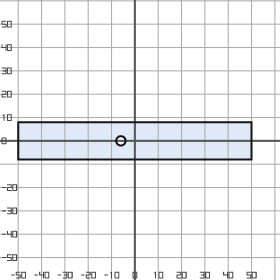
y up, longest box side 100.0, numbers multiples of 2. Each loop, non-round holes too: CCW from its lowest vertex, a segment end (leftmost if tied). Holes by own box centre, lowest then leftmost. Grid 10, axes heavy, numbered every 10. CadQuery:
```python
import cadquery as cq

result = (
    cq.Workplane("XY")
    .moveTo(-50.0, -8.0)
    .lineTo(50.0, -8.0)
    .lineTo(50.0, 8.0)
    .lineTo(-50.0, 8.0)
    .close()
    .moveTo(-6.0, 0.0)
    .circle(2.0)
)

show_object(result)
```